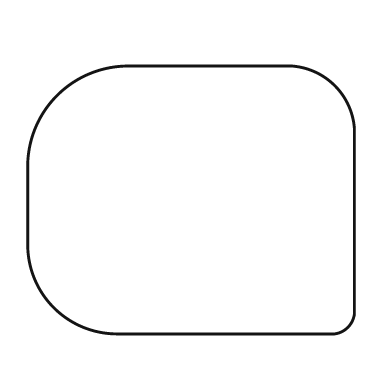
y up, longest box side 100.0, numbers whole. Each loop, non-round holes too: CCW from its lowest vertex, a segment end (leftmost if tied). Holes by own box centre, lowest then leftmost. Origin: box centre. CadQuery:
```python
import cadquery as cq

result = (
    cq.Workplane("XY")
    .moveTo(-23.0, -41.0)
    .lineTo(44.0, -41.0)
    .threePointArc((48.0, -39.0), (50.0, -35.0))
    .lineTo(50.0, 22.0)
    .threePointArc((44.0, 35.0), (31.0, 41.0))
    .lineTo(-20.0, 41.0)
    .threePointArc((-41.0, 32.0), (-50.0, 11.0))
    .lineTo(-50.0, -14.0)
    .threePointArc((-42.0, -33.0), (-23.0, -41.0))
    .close()
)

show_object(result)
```